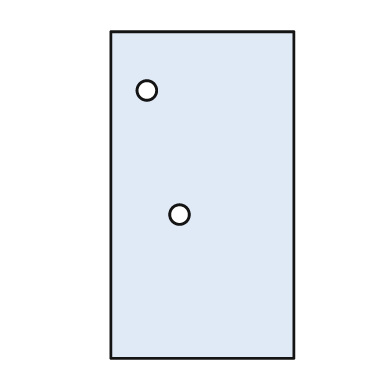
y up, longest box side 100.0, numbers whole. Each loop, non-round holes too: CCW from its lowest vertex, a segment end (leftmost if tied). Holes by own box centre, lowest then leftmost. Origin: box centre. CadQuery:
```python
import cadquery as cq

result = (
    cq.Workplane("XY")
    .moveTo(-28.0, -50.0)
    .lineTo(28.0, -50.0)
    .lineTo(28.0, 50.0)
    .lineTo(-28.0, 50.0)
    .close()
    .moveTo(-7.0, -6.0)
    .circle(3.0)
    .moveTo(-17.0, 32.0)
    .circle(3.0)
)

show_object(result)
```